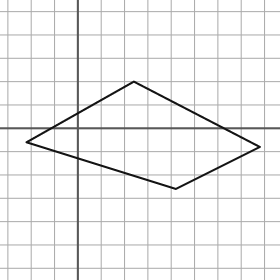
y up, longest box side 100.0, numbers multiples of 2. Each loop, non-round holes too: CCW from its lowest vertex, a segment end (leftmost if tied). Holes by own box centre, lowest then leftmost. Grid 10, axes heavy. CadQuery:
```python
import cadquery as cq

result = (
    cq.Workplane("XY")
    .moveTo(42.0, -26.0)
    .lineTo(78.0, -8.0)
    .lineTo(24.0, 20.0)
    .lineTo(-22.0, -6.0)
    .close()
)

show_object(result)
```